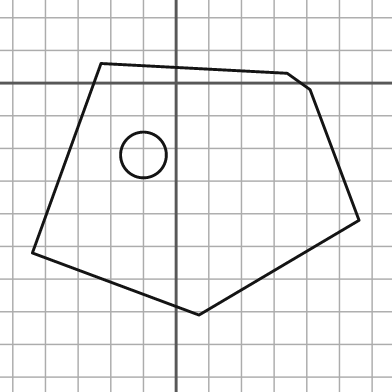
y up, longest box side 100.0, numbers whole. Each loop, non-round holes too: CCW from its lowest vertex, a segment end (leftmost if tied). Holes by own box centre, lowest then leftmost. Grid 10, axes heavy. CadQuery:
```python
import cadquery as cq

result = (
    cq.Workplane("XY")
    .moveTo(7.0, -71.0)
    .lineTo(56.0, -42.0)
    .lineTo(41.0, -2.0)
    .lineTo(34.0, 3.0)
    .lineTo(-23.0, 6.0)
    .lineTo(-44.0, -52.0)
    .close()
    .moveTo(-10.0, -22.0)
    .circle(7.0)
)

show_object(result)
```